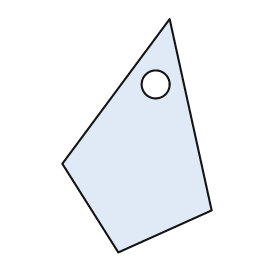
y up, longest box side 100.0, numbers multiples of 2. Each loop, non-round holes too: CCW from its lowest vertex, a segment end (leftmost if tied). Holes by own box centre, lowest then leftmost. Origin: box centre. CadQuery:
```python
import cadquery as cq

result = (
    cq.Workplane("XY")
    .moveTo(-8.0, -50.0)
    .lineTo(32.0, -32.0)
    .lineTo(14.0, 50.0)
    .lineTo(-32.0, -12.0)
    .close()
    .moveTo(8.0, 22.0)
    .circle(6.0)
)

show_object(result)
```